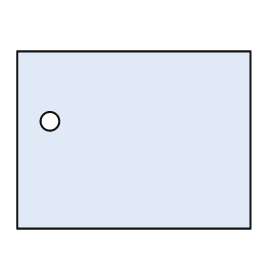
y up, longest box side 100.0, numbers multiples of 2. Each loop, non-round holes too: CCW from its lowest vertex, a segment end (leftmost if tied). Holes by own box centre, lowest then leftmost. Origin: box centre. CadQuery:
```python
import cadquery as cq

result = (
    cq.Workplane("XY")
    .moveTo(-50.0, -38.0)
    .lineTo(50.0, -38.0)
    .lineTo(50.0, 38.0)
    .lineTo(-50.0, 38.0)
    .close()
    .moveTo(-36.0, 8.0)
    .circle(4.0)
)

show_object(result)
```